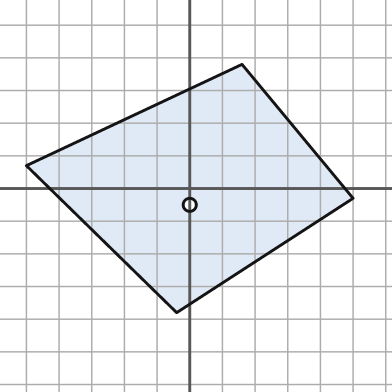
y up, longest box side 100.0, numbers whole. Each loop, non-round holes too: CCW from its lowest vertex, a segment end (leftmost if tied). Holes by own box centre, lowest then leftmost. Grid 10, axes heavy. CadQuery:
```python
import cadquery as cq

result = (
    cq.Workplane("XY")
    .moveTo(-4.0, -38.0)
    .lineTo(50.0, -3.0)
    .lineTo(16.0, 38.0)
    .lineTo(-50.0, 7.0)
    .close()
    .moveTo(0.0, -5.0)
    .circle(2.0)
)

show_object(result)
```